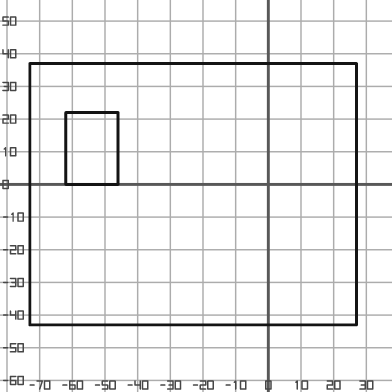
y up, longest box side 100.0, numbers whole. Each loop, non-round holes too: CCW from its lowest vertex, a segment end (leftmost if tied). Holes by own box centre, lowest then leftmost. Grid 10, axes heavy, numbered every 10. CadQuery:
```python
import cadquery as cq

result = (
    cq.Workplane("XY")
    .moveTo(-73.0, -43.0)
    .lineTo(27.0, -43.0)
    .lineTo(27.0, 37.0)
    .lineTo(-73.0, 37.0)
    .close()
    .moveTo(-62.0, 0.0)
    .lineTo(-46.0, 0.0)
    .lineTo(-46.0, 22.0)
    .lineTo(-62.0, 22.0)
    .close()
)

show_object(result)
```